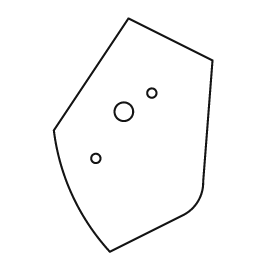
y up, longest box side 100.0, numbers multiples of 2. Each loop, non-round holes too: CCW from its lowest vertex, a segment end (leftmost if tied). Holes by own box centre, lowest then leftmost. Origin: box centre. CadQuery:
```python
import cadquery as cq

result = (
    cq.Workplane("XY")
    .moveTo(-10.0, -50.0)
    .lineTo(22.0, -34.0)
    .threePointArc((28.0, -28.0), (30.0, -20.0))
    .lineTo(34.0, 32.0)
    .lineTo(-2.0, 50.0)
    .lineTo(-34.0, 2.0)
    .threePointArc((-26.0, -26.0), (-10.0, -50.0))
    .close()
    .moveTo(-16.0, -10.0)
    .circle(2.0)
    .moveTo(-4.0, 10.0)
    .circle(4.0)
    .moveTo(8.0, 18.0)
    .circle(2.0)
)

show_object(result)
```